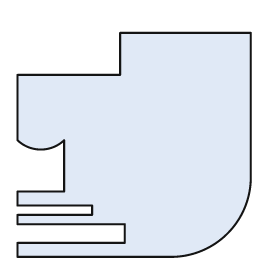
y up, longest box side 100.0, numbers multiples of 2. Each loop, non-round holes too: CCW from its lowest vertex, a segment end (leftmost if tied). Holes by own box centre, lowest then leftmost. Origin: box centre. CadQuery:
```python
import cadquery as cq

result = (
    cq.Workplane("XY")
    .moveTo(-50.0, -48.0)
    .lineTo(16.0, -48.0)
    .threePointArc((40.0, -38.0), (50.0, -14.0))
    .lineTo(50.0, 48.0)
    .lineTo(-6.0, 48.0)
    .lineTo(-6.0, 30.0)
    .lineTo(-50.0, 30.0)
    .lineTo(-50.0, 2.0)
    .threePointArc((-40.0, -2.0), (-30.0, 2.0))
    .lineTo(-30.0, -20.0)
    .lineTo(-50.0, -20.0)
    .lineTo(-50.0, -26.0)
    .lineTo(-18.0, -26.0)
    .lineTo(-18.0, -30.0)
    .lineTo(-50.0, -30.0)
    .lineTo(-50.0, -34.0)
    .lineTo(-4.0, -34.0)
    .lineTo(-4.0, -42.0)
    .lineTo(-50.0, -42.0)
    .close()
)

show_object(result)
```